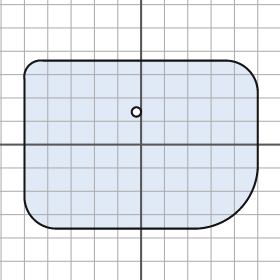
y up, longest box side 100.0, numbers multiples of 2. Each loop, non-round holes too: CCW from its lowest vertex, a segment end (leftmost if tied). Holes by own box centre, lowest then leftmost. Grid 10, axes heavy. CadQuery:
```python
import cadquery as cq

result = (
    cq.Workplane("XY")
    .moveTo(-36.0, -36.0)
    .lineTo(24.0, -36.0)
    .threePointArc((42.0, -28.0), (50.0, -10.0))
    .lineTo(50.0, 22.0)
    .threePointArc((46.0, 32.0), (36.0, 36.0))
    .lineTo(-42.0, 36.0)
    .threePointArc((-48.0, 34.0), (-50.0, 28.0))
    .lineTo(-50.0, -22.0)
    .threePointArc((-46.0, -32.0), (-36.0, -36.0))
    .close()
    .moveTo(-2.0, 14.0)
    .circle(2.0)
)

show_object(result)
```